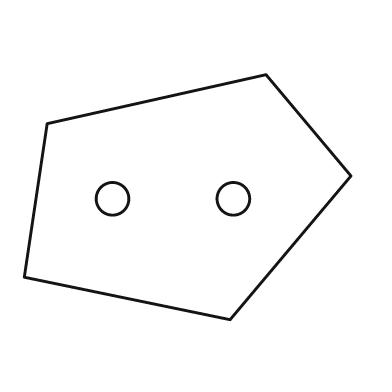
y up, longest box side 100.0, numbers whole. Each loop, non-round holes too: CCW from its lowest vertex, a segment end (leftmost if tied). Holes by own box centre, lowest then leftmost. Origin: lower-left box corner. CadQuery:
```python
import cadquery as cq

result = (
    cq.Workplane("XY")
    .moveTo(63.0, 0.0)
    .lineTo(100.0, 44.0)
    .lineTo(74.0, 75.0)
    .lineTo(7.0, 60.0)
    .lineTo(0.0, 13.0)
    .close()
    .moveTo(27.0, 37.0)
    .circle(5.0)
    .moveTo(64.0, 37.0)
    .circle(5.0)
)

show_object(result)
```